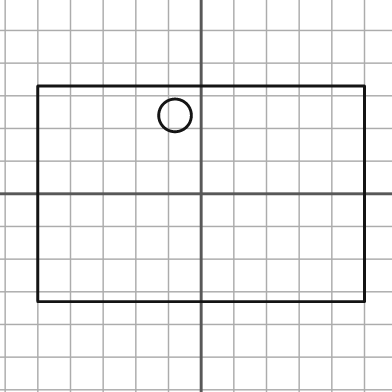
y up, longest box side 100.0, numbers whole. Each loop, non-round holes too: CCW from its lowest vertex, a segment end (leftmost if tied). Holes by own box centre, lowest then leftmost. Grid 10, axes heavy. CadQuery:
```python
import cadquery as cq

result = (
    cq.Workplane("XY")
    .moveTo(-50.0, -33.0)
    .lineTo(50.0, -33.0)
    .lineTo(50.0, 33.0)
    .lineTo(-50.0, 33.0)
    .close()
    .moveTo(-8.0, 24.0)
    .circle(5.0)
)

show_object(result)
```